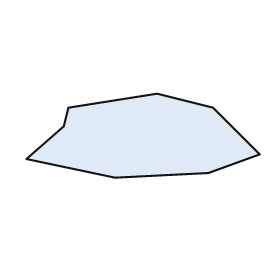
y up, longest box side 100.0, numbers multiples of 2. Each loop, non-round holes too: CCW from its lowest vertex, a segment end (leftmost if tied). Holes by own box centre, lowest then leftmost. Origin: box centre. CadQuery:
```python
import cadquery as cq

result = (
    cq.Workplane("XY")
    .moveTo(-12.0, -18.0)
    .lineTo(28.0, -16.0)
    .lineTo(50.0, -8.0)
    .lineTo(30.0, 12.0)
    .lineTo(6.0, 18.0)
    .lineTo(-32.0, 12.0)
    .lineTo(-34.0, 4.0)
    .lineTo(-50.0, -10.0)
    .close()
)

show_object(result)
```